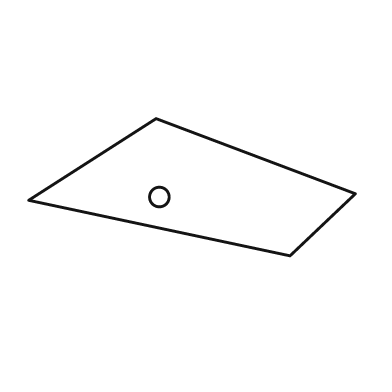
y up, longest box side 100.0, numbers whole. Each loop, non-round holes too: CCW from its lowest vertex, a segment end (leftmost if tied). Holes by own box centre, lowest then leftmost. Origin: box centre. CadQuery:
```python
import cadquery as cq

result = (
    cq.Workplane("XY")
    .moveTo(30.0, -21.0)
    .lineTo(50.0, -2.0)
    .lineTo(-11.0, 21.0)
    .lineTo(-50.0, -4.0)
    .close()
    .moveTo(-10.0, -3.0)
    .circle(3.0)
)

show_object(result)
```